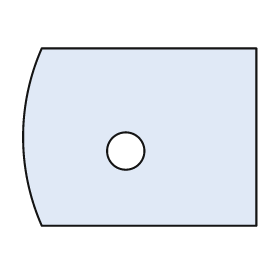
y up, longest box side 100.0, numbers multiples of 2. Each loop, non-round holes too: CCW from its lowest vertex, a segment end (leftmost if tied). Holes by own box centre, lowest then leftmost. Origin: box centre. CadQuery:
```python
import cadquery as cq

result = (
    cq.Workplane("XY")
    .moveTo(-42.0, -38.0)
    .lineTo(50.0, -38.0)
    .lineTo(50.0, 38.0)
    .lineTo(-42.0, 38.0)
    .threePointArc((-50.0, 0.0), (-42.0, -38.0))
    .close()
    .moveTo(-6.0, -6.0)
    .circle(8.0)
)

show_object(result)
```